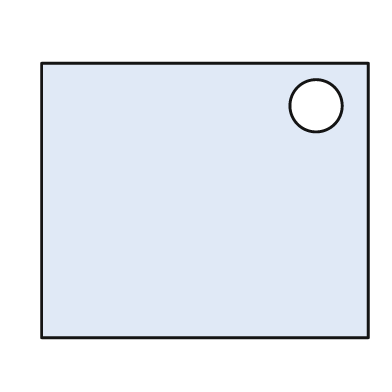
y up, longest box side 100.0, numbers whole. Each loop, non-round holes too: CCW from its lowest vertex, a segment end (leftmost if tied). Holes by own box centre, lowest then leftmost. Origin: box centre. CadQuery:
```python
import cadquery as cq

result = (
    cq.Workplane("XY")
    .moveTo(-50.0, -42.0)
    .lineTo(50.0, -42.0)
    .lineTo(50.0, 42.0)
    .lineTo(-50.0, 42.0)
    .close()
    .moveTo(34.0, 29.0)
    .circle(8.0)
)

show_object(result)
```